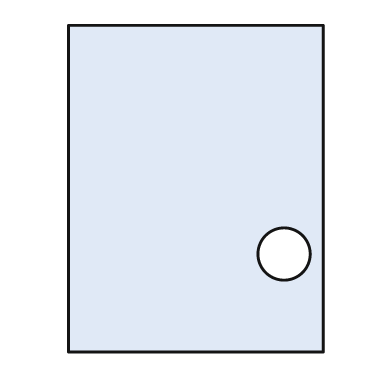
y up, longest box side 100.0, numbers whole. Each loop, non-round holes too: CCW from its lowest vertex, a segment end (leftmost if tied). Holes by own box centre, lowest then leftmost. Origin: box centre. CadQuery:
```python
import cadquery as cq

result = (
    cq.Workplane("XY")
    .moveTo(-39.0, -50.0)
    .lineTo(39.0, -50.0)
    .lineTo(39.0, 50.0)
    .lineTo(-39.0, 50.0)
    .close()
    .moveTo(27.0, -20.0)
    .circle(8.0)
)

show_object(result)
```